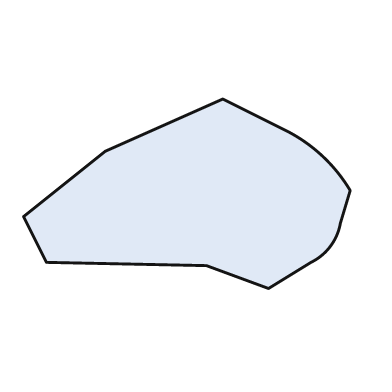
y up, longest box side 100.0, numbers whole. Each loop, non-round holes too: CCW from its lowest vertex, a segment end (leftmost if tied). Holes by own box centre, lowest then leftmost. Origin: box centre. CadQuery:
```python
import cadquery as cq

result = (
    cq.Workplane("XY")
    .moveTo(25.0, -29.0)
    .lineTo(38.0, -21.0)
    .threePointArc((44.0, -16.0), (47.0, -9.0))
    .lineTo(50.0, 1.0)
    .threePointArc((41.0, 12.0), (29.0, 20.0))
    .lineTo(11.0, 29.0)
    .lineTo(-25.0, 13.0)
    .lineTo(-50.0, -7.0)
    .lineTo(-43.0, -21.0)
    .lineTo(6.0, -22.0)
    .close()
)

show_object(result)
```